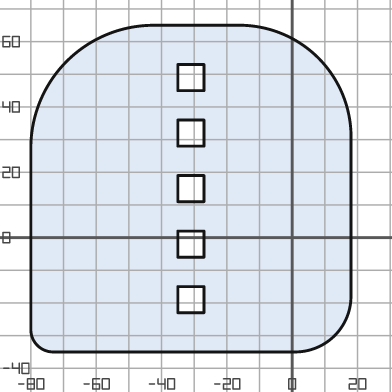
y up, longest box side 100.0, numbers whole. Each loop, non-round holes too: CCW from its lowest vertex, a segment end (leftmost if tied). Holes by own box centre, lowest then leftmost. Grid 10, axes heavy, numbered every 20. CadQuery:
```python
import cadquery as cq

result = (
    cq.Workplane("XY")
    .moveTo(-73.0, -35.0)
    .lineTo(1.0, -35.0)
    .threePointArc((13.0, -30.0), (18.0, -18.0))
    .lineTo(18.0, 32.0)
    .threePointArc((8.0, 55.0), (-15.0, 65.0))
    .lineTo(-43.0, 65.0)
    .threePointArc((-69.0, 54.0), (-80.0, 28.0))
    .lineTo(-80.0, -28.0)
    .threePointArc((-78.0, -33.0), (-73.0, -35.0))
    .close()
    .moveTo(-35.0, -23.0)
    .lineTo(-27.0, -23.0)
    .lineTo(-27.0, -15.0)
    .lineTo(-35.0, -15.0)
    .close()
    .moveTo(-35.0, -6.0)
    .lineTo(-27.0, -6.0)
    .lineTo(-27.0, 2.0)
    .lineTo(-35.0, 2.0)
    .close()
    .moveTo(-35.0, 11.0)
    .lineTo(-27.0, 11.0)
    .lineTo(-27.0, 19.0)
    .lineTo(-35.0, 19.0)
    .close()
    .moveTo(-35.0, 28.0)
    .lineTo(-27.0, 28.0)
    .lineTo(-27.0, 36.0)
    .lineTo(-35.0, 36.0)
    .close()
    .moveTo(-35.0, 45.0)
    .lineTo(-27.0, 45.0)
    .lineTo(-27.0, 53.0)
    .lineTo(-35.0, 53.0)
    .close()
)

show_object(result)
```